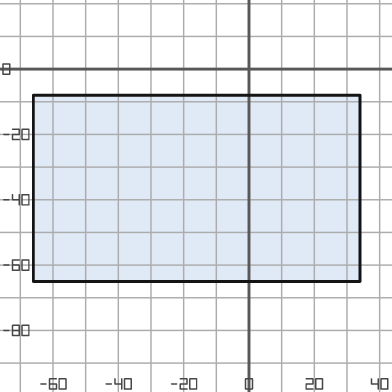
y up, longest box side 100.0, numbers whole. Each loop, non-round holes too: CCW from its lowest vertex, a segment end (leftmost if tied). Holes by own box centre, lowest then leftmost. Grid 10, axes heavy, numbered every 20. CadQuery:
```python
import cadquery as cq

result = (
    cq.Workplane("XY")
    .moveTo(-66.0, -65.0)
    .lineTo(34.0, -65.0)
    .lineTo(34.0, -8.0)
    .lineTo(-66.0, -8.0)
    .close()
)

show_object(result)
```